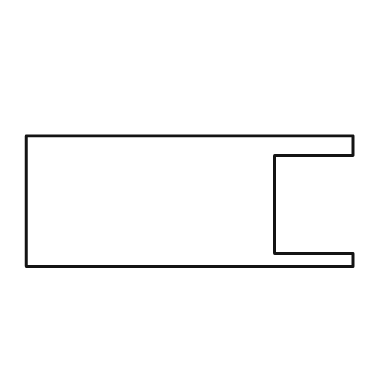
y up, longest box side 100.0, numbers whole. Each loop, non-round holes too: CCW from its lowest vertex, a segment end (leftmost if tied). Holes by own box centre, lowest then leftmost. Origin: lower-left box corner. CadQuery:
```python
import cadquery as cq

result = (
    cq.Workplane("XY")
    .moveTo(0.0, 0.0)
    .lineTo(100.0, 0.0)
    .lineTo(100.0, 4.0)
    .lineTo(76.0, 4.0)
    .lineTo(76.0, 34.0)
    .lineTo(100.0, 34.0)
    .lineTo(100.0, 40.0)
    .lineTo(0.0, 40.0)
    .close()
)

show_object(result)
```